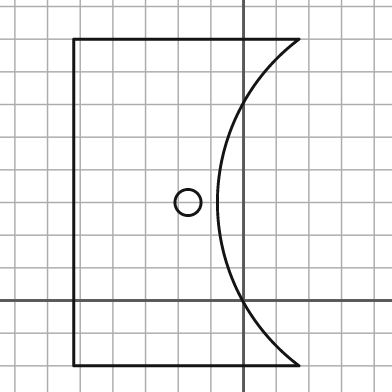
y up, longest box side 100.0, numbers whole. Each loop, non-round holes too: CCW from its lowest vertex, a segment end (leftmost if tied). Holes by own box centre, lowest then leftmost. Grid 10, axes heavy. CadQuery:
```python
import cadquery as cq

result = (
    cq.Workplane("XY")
    .moveTo(-52.0, -20.0)
    .lineTo(17.0, -20.0)
    .threePointArc((-8.0, 30.0), (17.0, 80.0))
    .lineTo(-52.0, 80.0)
    .close()
    .moveTo(-17.0, 30.0)
    .circle(4.0)
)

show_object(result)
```